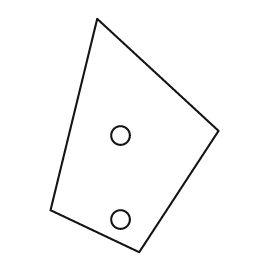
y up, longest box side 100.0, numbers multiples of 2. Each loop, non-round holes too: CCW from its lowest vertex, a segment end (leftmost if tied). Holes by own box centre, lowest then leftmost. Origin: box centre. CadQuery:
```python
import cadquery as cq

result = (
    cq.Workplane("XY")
    .moveTo(2.0, -50.0)
    .lineTo(36.0, 2.0)
    .lineTo(-16.0, 50.0)
    .lineTo(-36.0, -32.0)
    .close()
    .moveTo(-6.0, -36.0)
    .circle(4.0)
    .moveTo(-6.0, 0.0)
    .circle(4.0)
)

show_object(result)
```